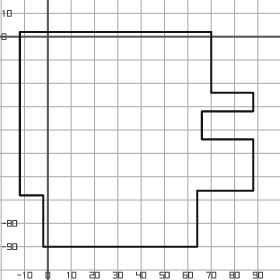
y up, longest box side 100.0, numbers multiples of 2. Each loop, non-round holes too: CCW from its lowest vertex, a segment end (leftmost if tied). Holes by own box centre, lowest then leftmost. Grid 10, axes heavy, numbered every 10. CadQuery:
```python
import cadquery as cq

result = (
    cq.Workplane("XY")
    .moveTo(-2.0, -90.0)
    .lineTo(64.0, -90.0)
    .lineTo(64.0, -66.0)
    .lineTo(88.0, -66.0)
    .lineTo(88.0, -44.0)
    .lineTo(66.0, -44.0)
    .lineTo(66.0, -32.0)
    .lineTo(88.0, -32.0)
    .lineTo(88.0, -24.0)
    .lineTo(70.0, -24.0)
    .lineTo(70.0, 2.0)
    .lineTo(-12.0, 2.0)
    .lineTo(-12.0, -68.0)
    .lineTo(-2.0, -68.0)
    .close()
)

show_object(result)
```